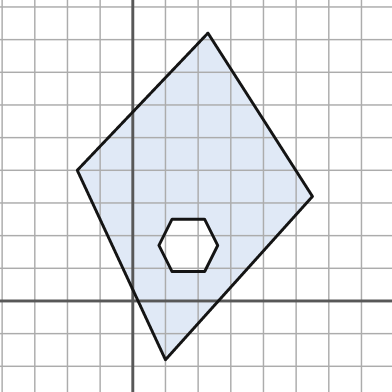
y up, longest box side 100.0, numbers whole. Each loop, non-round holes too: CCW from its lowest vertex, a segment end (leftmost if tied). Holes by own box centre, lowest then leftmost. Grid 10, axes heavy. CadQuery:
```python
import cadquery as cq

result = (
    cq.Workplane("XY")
    .moveTo(10.0, -18.0)
    .lineTo(55.0, 32.0)
    .lineTo(23.0, 82.0)
    .lineTo(-17.0, 40.0)
    .close()
    .moveTo(12.0, 9.0)
    .lineTo(22.0, 9.0)
    .lineTo(26.0, 17.0)
    .lineTo(22.0, 25.0)
    .lineTo(12.0, 25.0)
    .lineTo(8.0, 17.0)
    .close()
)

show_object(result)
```